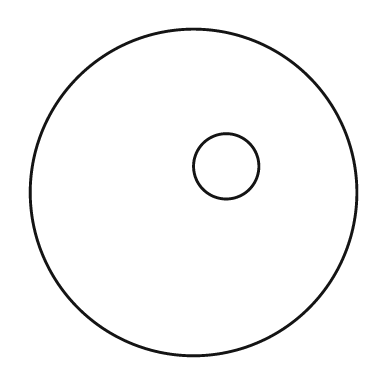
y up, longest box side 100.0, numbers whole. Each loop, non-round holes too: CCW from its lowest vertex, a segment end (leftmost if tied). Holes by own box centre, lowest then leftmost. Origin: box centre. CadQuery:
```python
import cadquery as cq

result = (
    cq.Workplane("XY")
    .moveTo(0.0, 0.0)
    .circle(50.0)
    .moveTo(10.0, 8.0)
    .circle(10.0)
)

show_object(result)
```